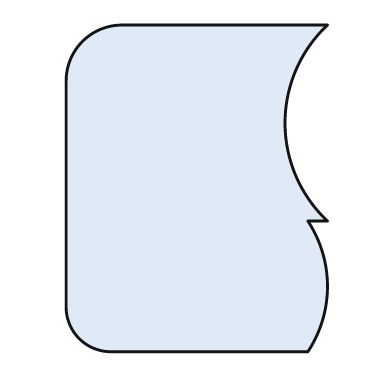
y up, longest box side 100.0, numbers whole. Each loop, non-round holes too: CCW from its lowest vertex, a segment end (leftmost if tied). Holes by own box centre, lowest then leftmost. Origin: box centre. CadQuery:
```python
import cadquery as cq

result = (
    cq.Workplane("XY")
    .moveTo(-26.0, -50.0)
    .lineTo(34.0, -50.0)
    .threePointArc((40.0, -30.0), (34.0, -10.0))
    .lineTo(40.0, -10.0)
    .threePointArc((27.0, 20.0), (40.0, 50.0))
    .lineTo(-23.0, 50.0)
    .threePointArc((-35.0, 45.0), (-40.0, 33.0))
    .lineTo(-40.0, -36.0)
    .threePointArc((-36.0, -46.0), (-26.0, -50.0))
    .close()
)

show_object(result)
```